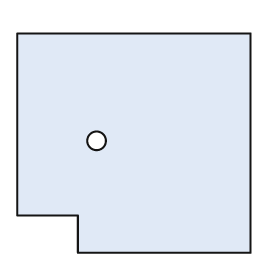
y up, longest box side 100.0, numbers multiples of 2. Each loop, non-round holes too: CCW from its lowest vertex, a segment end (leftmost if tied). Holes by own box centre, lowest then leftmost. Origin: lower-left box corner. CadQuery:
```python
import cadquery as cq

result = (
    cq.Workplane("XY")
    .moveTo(26.0, 0.0)
    .lineTo(100.0, 0.0)
    .lineTo(100.0, 94.0)
    .lineTo(0.0, 94.0)
    .lineTo(0.0, 16.0)
    .lineTo(26.0, 16.0)
    .close()
    .moveTo(34.0, 48.0)
    .circle(4.0)
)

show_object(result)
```